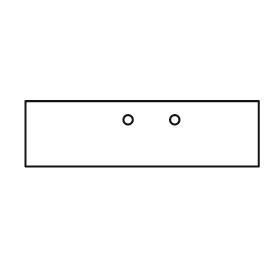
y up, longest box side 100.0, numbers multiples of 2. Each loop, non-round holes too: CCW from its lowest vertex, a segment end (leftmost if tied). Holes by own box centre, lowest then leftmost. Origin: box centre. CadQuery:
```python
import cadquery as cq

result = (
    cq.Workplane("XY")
    .moveTo(-50.0, -14.0)
    .lineTo(50.0, -14.0)
    .lineTo(50.0, 14.0)
    .lineTo(-50.0, 14.0)
    .close()
    .moveTo(-6.0, 6.0)
    .circle(2.0)
    .moveTo(14.0, 6.0)
    .circle(2.0)
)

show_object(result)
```